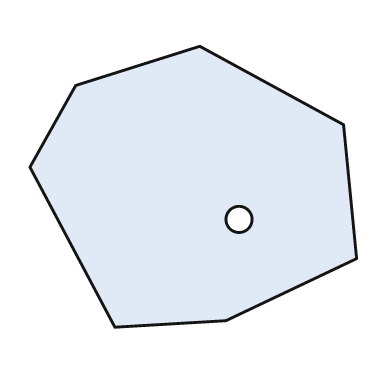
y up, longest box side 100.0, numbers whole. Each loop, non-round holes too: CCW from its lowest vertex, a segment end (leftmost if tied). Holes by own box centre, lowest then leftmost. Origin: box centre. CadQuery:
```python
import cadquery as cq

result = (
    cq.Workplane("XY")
    .moveTo(-24.0, -43.0)
    .lineTo(10.0, -41.0)
    .lineTo(50.0, -22.0)
    .lineTo(46.0, 19.0)
    .lineTo(2.0, 43.0)
    .lineTo(-36.0, 31.0)
    .lineTo(-50.0, 6.0)
    .close()
    .moveTo(14.0, -10.0)
    .circle(4.0)
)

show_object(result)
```